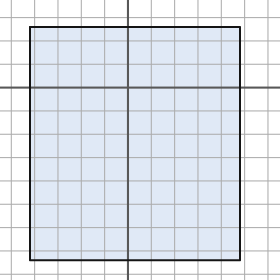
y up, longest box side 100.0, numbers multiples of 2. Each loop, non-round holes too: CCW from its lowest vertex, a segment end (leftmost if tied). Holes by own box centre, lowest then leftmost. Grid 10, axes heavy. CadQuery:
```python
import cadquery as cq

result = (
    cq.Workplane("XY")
    .moveTo(-42.0, -74.0)
    .lineTo(48.0, -74.0)
    .lineTo(48.0, 26.0)
    .lineTo(-42.0, 26.0)
    .close()
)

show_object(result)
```